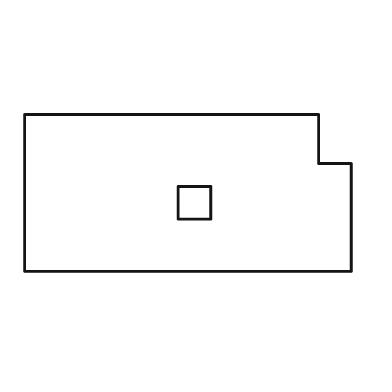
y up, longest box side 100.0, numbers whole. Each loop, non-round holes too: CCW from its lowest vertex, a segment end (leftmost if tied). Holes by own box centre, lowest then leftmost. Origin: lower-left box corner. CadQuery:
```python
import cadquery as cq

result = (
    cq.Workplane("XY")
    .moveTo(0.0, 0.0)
    .lineTo(100.0, 0.0)
    .lineTo(100.0, 33.0)
    .lineTo(90.0, 33.0)
    .lineTo(90.0, 48.0)
    .lineTo(0.0, 48.0)
    .close()
    .moveTo(47.0, 16.0)
    .lineTo(57.0, 16.0)
    .lineTo(57.0, 26.0)
    .lineTo(47.0, 26.0)
    .close()
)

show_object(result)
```